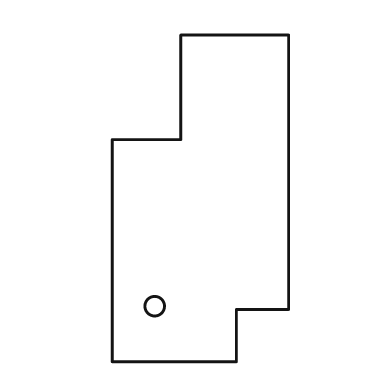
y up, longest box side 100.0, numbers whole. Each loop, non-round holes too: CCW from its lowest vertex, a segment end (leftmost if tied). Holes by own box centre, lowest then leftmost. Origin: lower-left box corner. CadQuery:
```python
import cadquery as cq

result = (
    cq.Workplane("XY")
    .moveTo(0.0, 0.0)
    .lineTo(38.0, 0.0)
    .lineTo(38.0, 16.0)
    .lineTo(54.0, 16.0)
    .lineTo(54.0, 100.0)
    .lineTo(21.0, 100.0)
    .lineTo(21.0, 68.0)
    .lineTo(0.0, 68.0)
    .close()
    .moveTo(13.0, 17.0)
    .circle(3.0)
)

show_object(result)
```